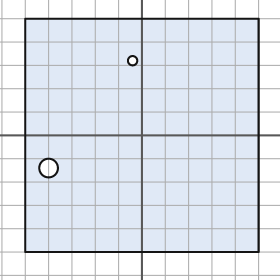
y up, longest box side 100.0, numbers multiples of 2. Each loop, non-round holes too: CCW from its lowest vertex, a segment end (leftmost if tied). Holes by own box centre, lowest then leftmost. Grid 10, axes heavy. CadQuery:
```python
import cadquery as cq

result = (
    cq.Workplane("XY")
    .moveTo(-50.0, -50.0)
    .lineTo(50.0, -50.0)
    .lineTo(50.0, 50.0)
    .lineTo(-50.0, 50.0)
    .close()
    .moveTo(-40.0, -14.0)
    .circle(4.0)
    .moveTo(-4.0, 32.0)
    .circle(2.0)
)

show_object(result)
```